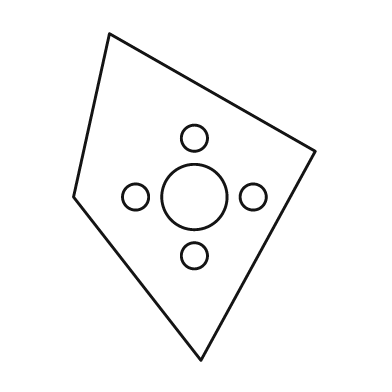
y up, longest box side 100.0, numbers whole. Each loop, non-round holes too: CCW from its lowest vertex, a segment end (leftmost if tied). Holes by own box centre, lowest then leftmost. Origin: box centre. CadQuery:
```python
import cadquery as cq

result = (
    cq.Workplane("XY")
    .moveTo(2.0, -50.0)
    .lineTo(37.0, 14.0)
    .lineTo(-26.0, 50.0)
    .lineTo(-37.0, 0.0)
    .close()
    .moveTo(0.0, -18.0)
    .circle(4.0)
    .moveTo(-18.0, 0.0)
    .circle(4.0)
    .moveTo(0.0, 0.0)
    .circle(10.0)
    .moveTo(18.0, 0.0)
    .circle(4.0)
    .moveTo(0.0, 18.0)
    .circle(4.0)
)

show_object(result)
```